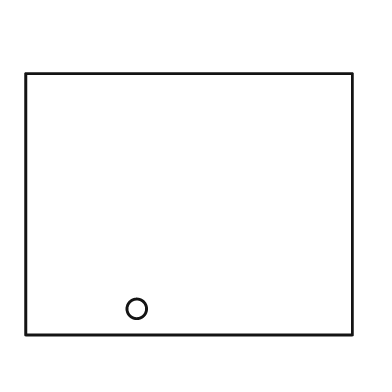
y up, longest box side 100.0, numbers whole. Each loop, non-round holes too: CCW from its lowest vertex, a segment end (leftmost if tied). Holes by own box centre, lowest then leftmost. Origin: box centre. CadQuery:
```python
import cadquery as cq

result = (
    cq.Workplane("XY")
    .moveTo(-50.0, -40.0)
    .lineTo(50.0, -40.0)
    .lineTo(50.0, 40.0)
    .lineTo(-50.0, 40.0)
    .close()
    .moveTo(-16.0, -32.0)
    .circle(3.0)
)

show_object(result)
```